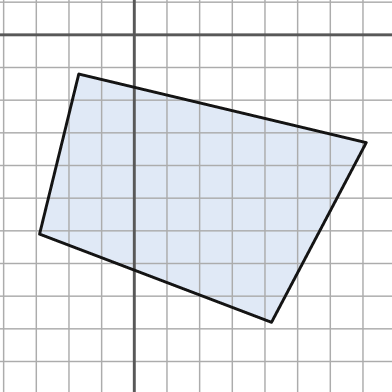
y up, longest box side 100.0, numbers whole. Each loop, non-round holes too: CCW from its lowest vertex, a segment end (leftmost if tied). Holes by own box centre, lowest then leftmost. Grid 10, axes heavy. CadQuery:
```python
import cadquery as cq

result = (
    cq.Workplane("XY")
    .moveTo(42.0, -88.0)
    .lineTo(71.0, -33.0)
    .lineTo(-17.0, -12.0)
    .lineTo(-29.0, -61.0)
    .close()
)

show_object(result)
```